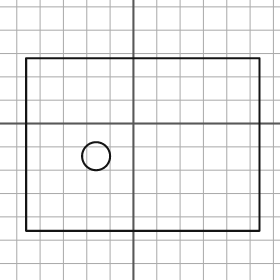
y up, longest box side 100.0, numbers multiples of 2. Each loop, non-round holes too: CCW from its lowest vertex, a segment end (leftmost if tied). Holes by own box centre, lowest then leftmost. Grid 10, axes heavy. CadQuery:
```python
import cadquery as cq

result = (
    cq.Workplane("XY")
    .moveTo(-46.0, -46.0)
    .lineTo(54.0, -46.0)
    .lineTo(54.0, 28.0)
    .lineTo(-46.0, 28.0)
    .close()
    .moveTo(-16.0, -14.0)
    .circle(6.0)
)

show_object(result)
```